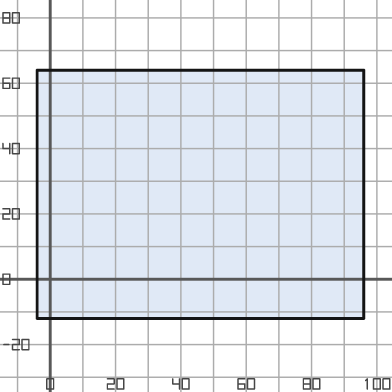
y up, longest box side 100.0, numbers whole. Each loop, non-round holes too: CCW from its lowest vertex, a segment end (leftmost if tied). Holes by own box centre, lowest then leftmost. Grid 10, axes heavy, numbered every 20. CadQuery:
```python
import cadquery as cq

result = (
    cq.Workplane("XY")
    .moveTo(-4.0, -12.0)
    .lineTo(96.0, -12.0)
    .lineTo(96.0, 64.0)
    .lineTo(-4.0, 64.0)
    .close()
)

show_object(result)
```